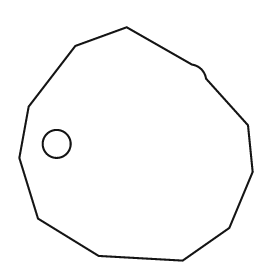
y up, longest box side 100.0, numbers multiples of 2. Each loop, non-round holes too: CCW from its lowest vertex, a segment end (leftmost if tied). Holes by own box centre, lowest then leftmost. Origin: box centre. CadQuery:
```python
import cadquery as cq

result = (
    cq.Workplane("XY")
    .moveTo(20.0, -50.0)
    .lineTo(40.0, -36.0)
    .lineTo(50.0, -12.0)
    .lineTo(48.0, 8.0)
    .lineTo(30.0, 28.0)
    .threePointArc((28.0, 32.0), (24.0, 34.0))
    .lineTo(-4.0, 50.0)
    .lineTo(-26.0, 42.0)
    .lineTo(-46.0, 16.0)
    .lineTo(-50.0, -6.0)
    .lineTo(-42.0, -32.0)
    .lineTo(-16.0, -48.0)
    .close()
    .moveTo(-34.0, 0.0)
    .circle(6.0)
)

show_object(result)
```